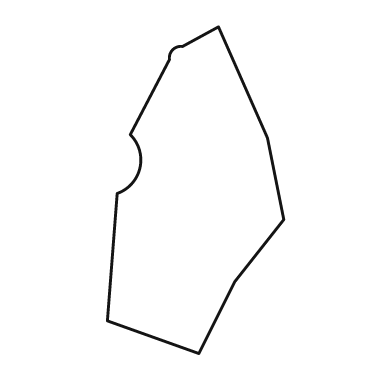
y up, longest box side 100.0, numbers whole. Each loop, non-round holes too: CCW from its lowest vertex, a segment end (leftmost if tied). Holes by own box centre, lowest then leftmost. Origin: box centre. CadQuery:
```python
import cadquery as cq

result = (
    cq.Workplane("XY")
    .moveTo(1.0, -50.0)
    .lineTo(12.0, -28.0)
    .lineTo(27.0, -9.0)
    .lineTo(22.0, 16.0)
    .lineTo(7.0, 50.0)
    .lineTo(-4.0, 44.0)
    .threePointArc((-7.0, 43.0), (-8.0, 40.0))
    .lineTo(-20.0, 17.0)
    .threePointArc((-17.0, 7.0), (-24.0, -1.0))
    .lineTo(-27.0, -40.0)
    .close()
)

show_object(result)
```